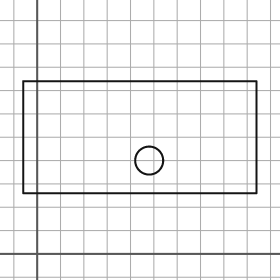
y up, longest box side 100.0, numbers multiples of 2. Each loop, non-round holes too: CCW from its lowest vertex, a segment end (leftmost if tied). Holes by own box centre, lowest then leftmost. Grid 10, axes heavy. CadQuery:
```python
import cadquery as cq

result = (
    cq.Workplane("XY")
    .moveTo(-6.0, 26.0)
    .lineTo(94.0, 26.0)
    .lineTo(94.0, 74.0)
    .lineTo(-6.0, 74.0)
    .close()
    .moveTo(48.0, 40.0)
    .circle(6.0)
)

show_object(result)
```